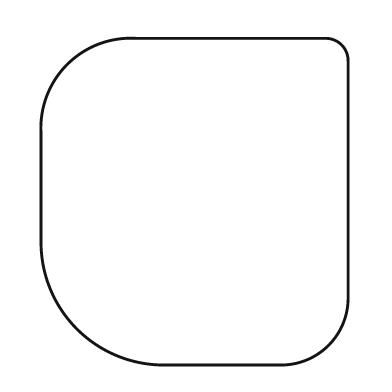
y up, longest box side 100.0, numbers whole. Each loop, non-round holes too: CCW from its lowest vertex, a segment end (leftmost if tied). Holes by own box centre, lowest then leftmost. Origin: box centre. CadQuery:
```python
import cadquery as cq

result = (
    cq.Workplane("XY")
    .moveTo(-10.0, -50.0)
    .lineTo(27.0, -50.0)
    .threePointArc((41.0, -44.0), (47.0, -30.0))
    .lineTo(47.0, 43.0)
    .threePointArc((45.0, 48.0), (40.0, 50.0))
    .lineTo(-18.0, 50.0)
    .threePointArc((-39.0, 42.0), (-47.0, 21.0))
    .lineTo(-47.0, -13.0)
    .threePointArc((-36.0, -39.0), (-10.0, -50.0))
    .close()
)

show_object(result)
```